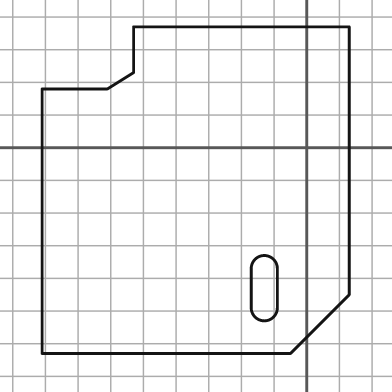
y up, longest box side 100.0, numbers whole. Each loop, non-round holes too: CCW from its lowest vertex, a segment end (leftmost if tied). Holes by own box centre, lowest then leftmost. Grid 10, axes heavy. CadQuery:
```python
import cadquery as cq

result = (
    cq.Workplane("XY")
    .moveTo(-81.0, -63.0)
    .lineTo(-5.0, -63.0)
    .lineTo(13.0, -45.0)
    .lineTo(13.0, 37.0)
    .lineTo(-53.0, 37.0)
    .lineTo(-53.0, 23.0)
    .lineTo(-61.0, 18.0)
    .lineTo(-81.0, 18.0)
    .close()
    .moveTo(-17.0, -49.0)
    .threePointArc((-13.0, -53.0), (-9.0, -49.0))
    .lineTo(-9.0, -37.0)
    .threePointArc((-13.0, -33.0), (-17.0, -37.0))
    .close()
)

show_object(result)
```